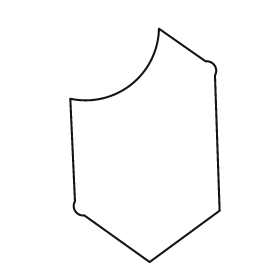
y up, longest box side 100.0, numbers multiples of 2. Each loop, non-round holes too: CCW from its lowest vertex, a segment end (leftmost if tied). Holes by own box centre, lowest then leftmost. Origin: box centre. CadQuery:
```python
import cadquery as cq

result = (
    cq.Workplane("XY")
    .moveTo(2.0, -50.0)
    .lineTo(32.0, -28.0)
    .lineTo(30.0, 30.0)
    .threePointArc((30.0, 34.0), (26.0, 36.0))
    .lineTo(6.0, 50.0)
    .threePointArc((-6.0, 26.0), (-32.0, 20.0))
    .lineTo(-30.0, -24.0)
    .threePointArc((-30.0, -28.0), (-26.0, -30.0))
    .close()
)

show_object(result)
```